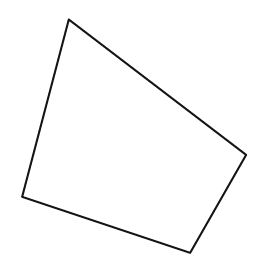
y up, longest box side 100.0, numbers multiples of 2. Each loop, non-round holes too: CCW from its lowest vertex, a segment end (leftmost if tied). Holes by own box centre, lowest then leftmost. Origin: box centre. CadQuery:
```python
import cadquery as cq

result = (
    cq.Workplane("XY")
    .moveTo(24.0, -50.0)
    .lineTo(48.0, -8.0)
    .lineTo(-28.0, 50.0)
    .lineTo(-48.0, -26.0)
    .close()
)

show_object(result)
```